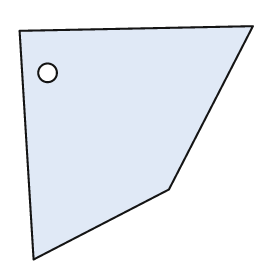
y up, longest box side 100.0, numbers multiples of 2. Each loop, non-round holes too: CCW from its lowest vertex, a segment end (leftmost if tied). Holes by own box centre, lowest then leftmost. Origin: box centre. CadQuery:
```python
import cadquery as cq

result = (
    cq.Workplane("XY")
    .moveTo(-44.0, -50.0)
    .lineTo(14.0, -20.0)
    .lineTo(50.0, 50.0)
    .lineTo(-50.0, 48.0)
    .close()
    .moveTo(-38.0, 30.0)
    .circle(4.0)
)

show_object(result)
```